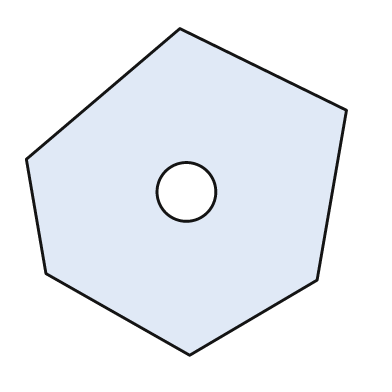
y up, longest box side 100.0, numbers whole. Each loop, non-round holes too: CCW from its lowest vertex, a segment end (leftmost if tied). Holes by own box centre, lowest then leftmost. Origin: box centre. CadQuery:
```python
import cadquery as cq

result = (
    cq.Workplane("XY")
    .moveTo(1.0, -50.0)
    .lineTo(40.0, -27.0)
    .lineTo(49.0, 25.0)
    .lineTo(-2.0, 50.0)
    .lineTo(-49.0, 10.0)
    .lineTo(-43.0, -25.0)
    .close()
    .moveTo(0.0, 0.0)
    .circle(9.0)
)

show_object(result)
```